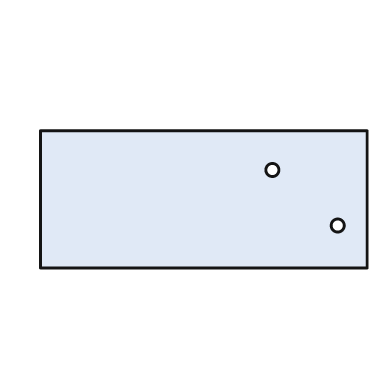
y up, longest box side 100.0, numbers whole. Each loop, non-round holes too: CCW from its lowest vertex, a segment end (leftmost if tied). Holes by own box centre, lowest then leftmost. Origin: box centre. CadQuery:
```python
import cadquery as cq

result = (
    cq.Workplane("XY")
    .moveTo(-50.0, -21.0)
    .lineTo(50.0, -21.0)
    .lineTo(50.0, 21.0)
    .lineTo(-50.0, 21.0)
    .close()
    .moveTo(41.0, -8.0)
    .circle(2.0)
    .moveTo(21.0, 9.0)
    .circle(2.0)
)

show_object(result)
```